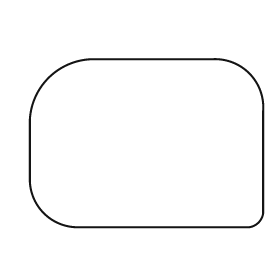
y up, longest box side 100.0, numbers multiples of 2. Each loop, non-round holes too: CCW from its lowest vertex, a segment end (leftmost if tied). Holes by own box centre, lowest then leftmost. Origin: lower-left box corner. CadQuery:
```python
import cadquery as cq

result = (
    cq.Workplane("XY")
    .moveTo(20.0, 0.0)
    .lineTo(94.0, 0.0)
    .threePointArc((98.0, 2.0), (100.0, 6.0))
    .lineTo(100.0, 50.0)
    .threePointArc((94.0, 66.0), (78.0, 72.0))
    .lineTo(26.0, 72.0)
    .threePointArc((8.0, 64.0), (0.0, 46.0))
    .lineTo(0.0, 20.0)
    .threePointArc((6.0, 6.0), (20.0, 0.0))
    .close()
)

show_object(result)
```